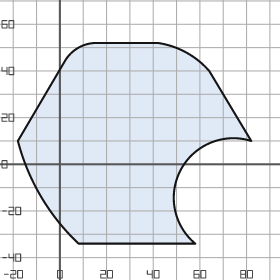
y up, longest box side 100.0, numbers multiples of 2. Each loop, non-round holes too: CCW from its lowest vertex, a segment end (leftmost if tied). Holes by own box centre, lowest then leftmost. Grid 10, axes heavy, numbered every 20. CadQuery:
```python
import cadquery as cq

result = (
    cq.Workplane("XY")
    .moveTo(8.0, -34.0)
    .lineTo(58.0, -34.0)
    .threePointArc((52.0, -2.0), (82.0, 10.0))
    .lineTo(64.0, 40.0)
    .threePointArc((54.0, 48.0), (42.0, 52.0))
    .lineTo(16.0, 52.0)
    .threePointArc((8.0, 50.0), (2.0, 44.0))
    .lineTo(-18.0, 10.0)
    .threePointArc((-8.0, -14.0), (8.0, -34.0))
    .close()
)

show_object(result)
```